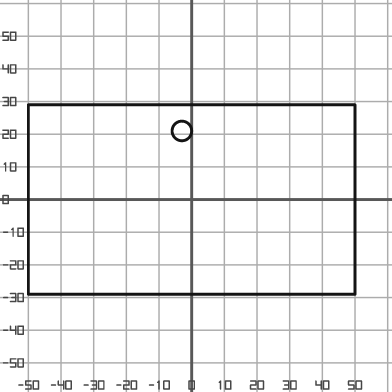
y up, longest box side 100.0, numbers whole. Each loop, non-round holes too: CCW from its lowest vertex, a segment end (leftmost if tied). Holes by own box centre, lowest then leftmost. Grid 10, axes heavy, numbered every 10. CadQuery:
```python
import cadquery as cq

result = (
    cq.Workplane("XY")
    .moveTo(-50.0, -29.0)
    .lineTo(50.0, -29.0)
    .lineTo(50.0, 29.0)
    .lineTo(-50.0, 29.0)
    .close()
    .moveTo(-3.0, 21.0)
    .circle(3.0)
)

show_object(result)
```